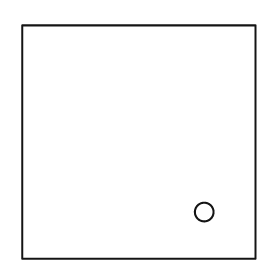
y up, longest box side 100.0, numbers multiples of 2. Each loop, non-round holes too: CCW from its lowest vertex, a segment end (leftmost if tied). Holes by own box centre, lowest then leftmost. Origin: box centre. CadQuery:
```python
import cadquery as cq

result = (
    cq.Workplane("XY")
    .moveTo(-50.0, -50.0)
    .lineTo(50.0, -50.0)
    .lineTo(50.0, 50.0)
    .lineTo(-50.0, 50.0)
    .close()
    .moveTo(28.0, -30.0)
    .circle(4.0)
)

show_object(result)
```